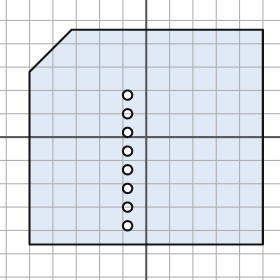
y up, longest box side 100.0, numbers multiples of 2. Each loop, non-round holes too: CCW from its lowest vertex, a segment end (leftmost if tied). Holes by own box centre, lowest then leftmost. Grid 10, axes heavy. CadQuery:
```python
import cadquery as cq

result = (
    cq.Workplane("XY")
    .moveTo(-50.0, -46.0)
    .lineTo(50.0, -46.0)
    .lineTo(50.0, 46.0)
    .lineTo(-32.0, 46.0)
    .lineTo(-50.0, 28.0)
    .close()
    .moveTo(-8.0, -38.0)
    .circle(2.0)
    .moveTo(-8.0, -30.0)
    .circle(2.0)
    .moveTo(-8.0, -22.0)
    .circle(2.0)
    .moveTo(-8.0, -14.0)
    .circle(2.0)
    .moveTo(-8.0, -6.0)
    .circle(2.0)
    .moveTo(-8.0, 2.0)
    .circle(2.0)
    .moveTo(-8.0, 10.0)
    .circle(2.0)
    .moveTo(-8.0, 18.0)
    .circle(2.0)
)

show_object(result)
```